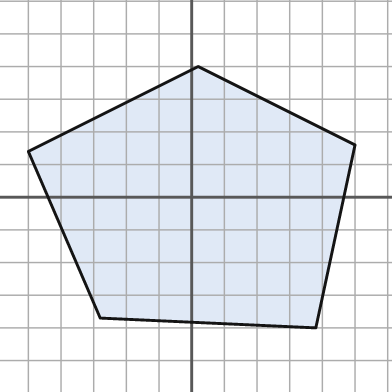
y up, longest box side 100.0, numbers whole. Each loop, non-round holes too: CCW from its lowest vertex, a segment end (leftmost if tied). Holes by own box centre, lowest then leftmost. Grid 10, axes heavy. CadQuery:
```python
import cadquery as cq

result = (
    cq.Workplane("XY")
    .moveTo(38.0, -40.0)
    .lineTo(50.0, 16.0)
    .lineTo(2.0, 40.0)
    .lineTo(-50.0, 14.0)
    .lineTo(-28.0, -37.0)
    .close()
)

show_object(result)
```